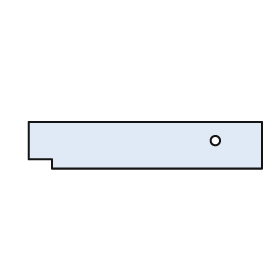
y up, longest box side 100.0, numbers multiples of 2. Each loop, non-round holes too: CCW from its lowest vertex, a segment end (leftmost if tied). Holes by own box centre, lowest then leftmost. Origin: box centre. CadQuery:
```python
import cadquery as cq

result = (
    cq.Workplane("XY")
    .moveTo(-40.0, -10.0)
    .lineTo(50.0, -10.0)
    .lineTo(50.0, 10.0)
    .lineTo(-50.0, 10.0)
    .lineTo(-50.0, -6.0)
    .lineTo(-40.0, -6.0)
    .close()
    .moveTo(30.0, 2.0)
    .circle(2.0)
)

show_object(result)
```